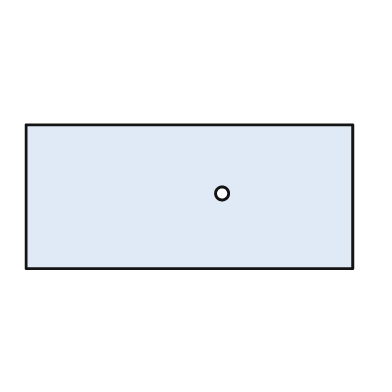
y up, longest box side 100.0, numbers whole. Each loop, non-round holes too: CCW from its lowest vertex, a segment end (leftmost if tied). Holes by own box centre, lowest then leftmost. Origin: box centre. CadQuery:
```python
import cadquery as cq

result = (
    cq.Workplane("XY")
    .moveTo(-50.0, -22.0)
    .lineTo(50.0, -22.0)
    .lineTo(50.0, 22.0)
    .lineTo(-50.0, 22.0)
    .close()
    .moveTo(10.0, 1.0)
    .circle(2.0)
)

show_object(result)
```